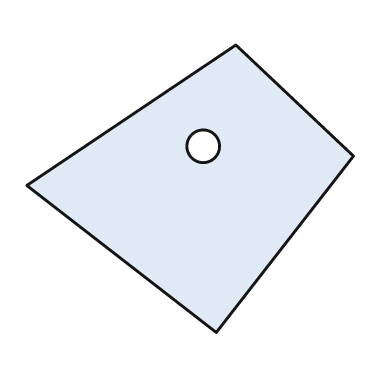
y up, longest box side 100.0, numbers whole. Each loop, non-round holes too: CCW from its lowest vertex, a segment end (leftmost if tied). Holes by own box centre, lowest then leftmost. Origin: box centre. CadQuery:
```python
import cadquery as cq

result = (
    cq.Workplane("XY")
    .moveTo(8.0, -44.0)
    .lineTo(50.0, 10.0)
    .lineTo(14.0, 44.0)
    .lineTo(-50.0, 1.0)
    .close()
    .moveTo(4.0, 13.0)
    .circle(5.0)
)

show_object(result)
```